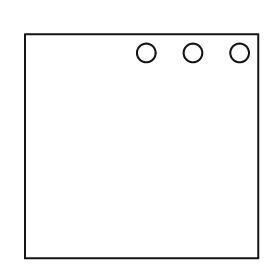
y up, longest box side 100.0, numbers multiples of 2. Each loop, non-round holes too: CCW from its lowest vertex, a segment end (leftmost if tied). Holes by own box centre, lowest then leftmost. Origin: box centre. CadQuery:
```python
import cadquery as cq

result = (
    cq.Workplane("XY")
    .moveTo(-50.0, -48.0)
    .lineTo(50.0, -48.0)
    .lineTo(50.0, 48.0)
    .lineTo(-50.0, 48.0)
    .close()
    .moveTo(2.0, 40.0)
    .circle(4.0)
    .moveTo(22.0, 40.0)
    .circle(4.0)
    .moveTo(42.0, 40.0)
    .circle(4.0)
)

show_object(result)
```